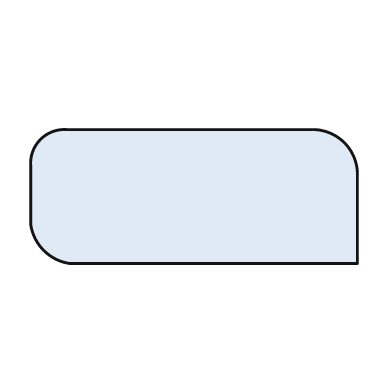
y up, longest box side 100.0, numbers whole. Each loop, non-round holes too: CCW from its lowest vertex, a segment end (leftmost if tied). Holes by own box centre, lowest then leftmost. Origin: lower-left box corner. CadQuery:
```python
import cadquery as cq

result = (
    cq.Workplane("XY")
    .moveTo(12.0, 0.0)
    .lineTo(100.0, 0.0)
    .lineTo(100.0, 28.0)
    .threePointArc((96.0, 37.0), (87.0, 41.0))
    .lineTo(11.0, 41.0)
    .threePointArc((3.0, 38.0), (0.0, 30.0))
    .lineTo(0.0, 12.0)
    .threePointArc((4.0, 4.0), (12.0, 0.0))
    .close()
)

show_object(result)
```